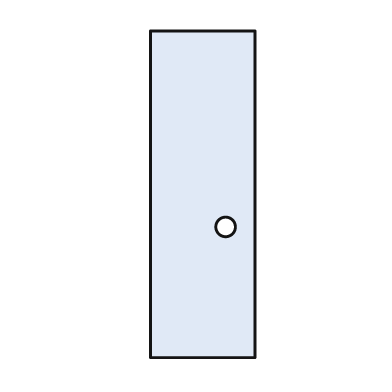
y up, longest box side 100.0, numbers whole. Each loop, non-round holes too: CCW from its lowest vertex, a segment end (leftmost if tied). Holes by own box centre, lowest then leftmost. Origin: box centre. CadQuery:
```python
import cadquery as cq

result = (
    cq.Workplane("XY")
    .moveTo(-16.0, -50.0)
    .lineTo(16.0, -50.0)
    .lineTo(16.0, 50.0)
    .lineTo(-16.0, 50.0)
    .close()
    .moveTo(7.0, -10.0)
    .circle(3.0)
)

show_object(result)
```